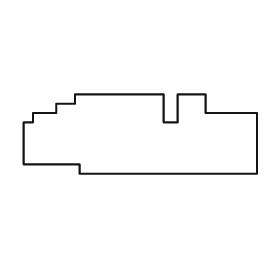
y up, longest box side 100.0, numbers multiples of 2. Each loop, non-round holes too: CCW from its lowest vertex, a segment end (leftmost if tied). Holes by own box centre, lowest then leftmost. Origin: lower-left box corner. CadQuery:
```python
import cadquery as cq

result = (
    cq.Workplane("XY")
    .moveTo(24.0, 0.0)
    .lineTo(100.0, 0.0)
    .lineTo(100.0, 26.0)
    .lineTo(78.0, 26.0)
    .lineTo(78.0, 34.0)
    .lineTo(66.0, 34.0)
    .lineTo(66.0, 22.0)
    .lineTo(60.0, 22.0)
    .lineTo(60.0, 34.0)
    .lineTo(22.0, 34.0)
    .lineTo(22.0, 30.0)
    .lineTo(14.0, 30.0)
    .lineTo(14.0, 26.0)
    .lineTo(4.0, 26.0)
    .lineTo(4.0, 22.0)
    .lineTo(0.0, 22.0)
    .lineTo(0.0, 4.0)
    .lineTo(24.0, 4.0)
    .close()
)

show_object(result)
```